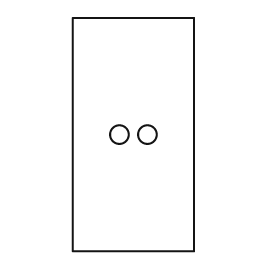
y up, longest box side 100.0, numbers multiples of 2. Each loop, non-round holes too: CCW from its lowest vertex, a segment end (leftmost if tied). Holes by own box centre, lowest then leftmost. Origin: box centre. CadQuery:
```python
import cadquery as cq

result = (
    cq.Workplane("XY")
    .moveTo(-26.0, -50.0)
    .lineTo(26.0, -50.0)
    .lineTo(26.0, 50.0)
    .lineTo(-26.0, 50.0)
    .close()
    .moveTo(-6.0, 0.0)
    .circle(4.0)
    .moveTo(6.0, 0.0)
    .circle(4.0)
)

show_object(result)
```